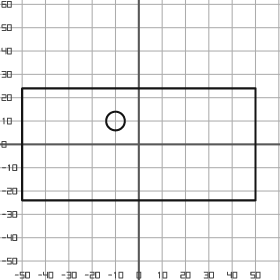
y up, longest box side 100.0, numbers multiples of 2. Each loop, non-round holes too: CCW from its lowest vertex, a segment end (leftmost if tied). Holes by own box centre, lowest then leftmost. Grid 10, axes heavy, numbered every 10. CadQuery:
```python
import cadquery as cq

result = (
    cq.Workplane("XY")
    .moveTo(-50.0, -24.0)
    .lineTo(50.0, -24.0)
    .lineTo(50.0, 24.0)
    .lineTo(-50.0, 24.0)
    .close()
    .moveTo(-10.0, 10.0)
    .circle(4.0)
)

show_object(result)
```